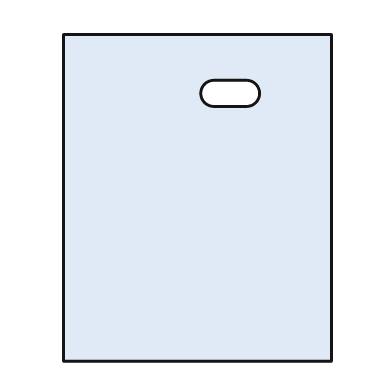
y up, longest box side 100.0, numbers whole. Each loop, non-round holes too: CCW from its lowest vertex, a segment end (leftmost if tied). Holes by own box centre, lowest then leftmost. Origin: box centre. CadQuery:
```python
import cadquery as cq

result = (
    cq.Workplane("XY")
    .moveTo(-41.0, -50.0)
    .lineTo(41.0, -50.0)
    .lineTo(41.0, 50.0)
    .lineTo(-41.0, 50.0)
    .close()
    .moveTo(5.0, 28.0)
    .lineTo(15.0, 28.0)
    .threePointArc((19.0, 32.0), (15.0, 36.0))
    .lineTo(5.0, 36.0)
    .threePointArc((1.0, 32.0), (5.0, 28.0))
    .close()
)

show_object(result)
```